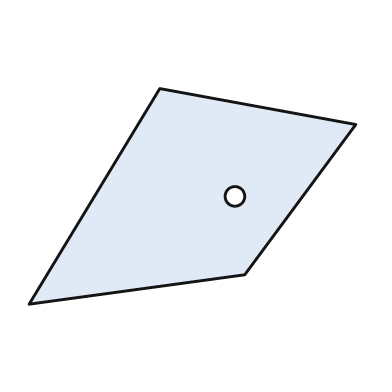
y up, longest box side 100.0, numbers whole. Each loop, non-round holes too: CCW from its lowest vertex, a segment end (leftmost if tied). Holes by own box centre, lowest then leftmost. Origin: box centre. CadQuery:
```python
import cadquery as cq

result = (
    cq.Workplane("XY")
    .moveTo(-50.0, -33.0)
    .lineTo(16.0, -24.0)
    .lineTo(50.0, 22.0)
    .lineTo(-10.0, 33.0)
    .close()
    .moveTo(13.0, 0.0)
    .circle(3.0)
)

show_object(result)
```